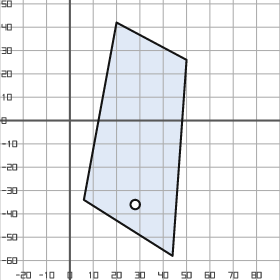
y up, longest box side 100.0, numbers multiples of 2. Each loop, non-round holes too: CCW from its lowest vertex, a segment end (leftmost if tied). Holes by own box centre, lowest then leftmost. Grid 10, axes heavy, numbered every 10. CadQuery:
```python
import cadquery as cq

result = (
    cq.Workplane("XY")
    .moveTo(44.0, -58.0)
    .lineTo(50.0, 26.0)
    .lineTo(20.0, 42.0)
    .lineTo(6.0, -34.0)
    .close()
    .moveTo(28.0, -36.0)
    .circle(2.0)
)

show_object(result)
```